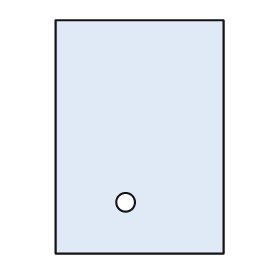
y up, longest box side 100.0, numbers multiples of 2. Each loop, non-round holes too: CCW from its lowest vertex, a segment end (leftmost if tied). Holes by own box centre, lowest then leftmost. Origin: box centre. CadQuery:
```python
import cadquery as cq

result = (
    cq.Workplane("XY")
    .moveTo(-36.0, -50.0)
    .lineTo(36.0, -50.0)
    .lineTo(36.0, 50.0)
    .lineTo(-36.0, 50.0)
    .close()
    .moveTo(-6.0, -28.0)
    .circle(4.0)
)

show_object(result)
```